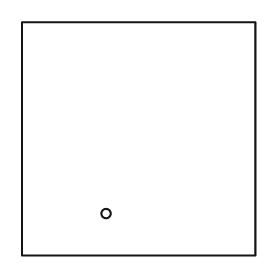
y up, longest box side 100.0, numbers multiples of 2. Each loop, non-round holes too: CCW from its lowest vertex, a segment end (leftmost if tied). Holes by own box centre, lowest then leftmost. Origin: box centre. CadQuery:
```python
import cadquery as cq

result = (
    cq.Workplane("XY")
    .moveTo(-50.0, -50.0)
    .lineTo(50.0, -50.0)
    .lineTo(50.0, 50.0)
    .lineTo(-50.0, 50.0)
    .close()
    .moveTo(-14.0, -32.0)
    .circle(2.0)
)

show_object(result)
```